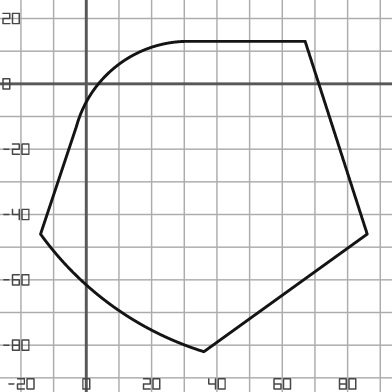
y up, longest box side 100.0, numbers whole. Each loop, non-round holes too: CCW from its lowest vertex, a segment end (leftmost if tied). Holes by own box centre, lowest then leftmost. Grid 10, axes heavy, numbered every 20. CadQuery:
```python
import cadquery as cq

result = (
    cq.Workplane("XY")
    .moveTo(36.0, -82.0)
    .lineTo(86.0, -46.0)
    .lineTo(67.0, 13.0)
    .lineTo(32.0, 13.0)
    .threePointArc((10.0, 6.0), (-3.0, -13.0))
    .lineTo(-14.0, -46.0)
    .threePointArc((8.0, -68.0), (36.0, -82.0))
    .close()
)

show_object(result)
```